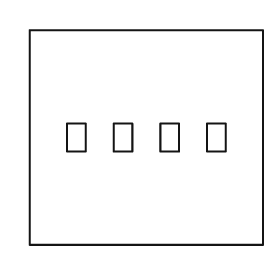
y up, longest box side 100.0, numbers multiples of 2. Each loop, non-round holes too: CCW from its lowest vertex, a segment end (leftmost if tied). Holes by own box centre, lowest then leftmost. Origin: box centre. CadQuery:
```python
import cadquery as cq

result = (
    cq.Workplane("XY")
    .moveTo(-50.0, -46.0)
    .lineTo(50.0, -46.0)
    .lineTo(50.0, 46.0)
    .lineTo(-50.0, 46.0)
    .close()
    .moveTo(-34.0, -6.0)
    .lineTo(-26.0, -6.0)
    .lineTo(-26.0, 6.0)
    .lineTo(-34.0, 6.0)
    .close()
    .moveTo(-14.0, -6.0)
    .lineTo(-6.0, -6.0)
    .lineTo(-6.0, 6.0)
    .lineTo(-14.0, 6.0)
    .close()
    .moveTo(6.0, -6.0)
    .lineTo(14.0, -6.0)
    .lineTo(14.0, 6.0)
    .lineTo(6.0, 6.0)
    .close()
    .moveTo(26.0, -6.0)
    .lineTo(34.0, -6.0)
    .lineTo(34.0, 6.0)
    .lineTo(26.0, 6.0)
    .close()
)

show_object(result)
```